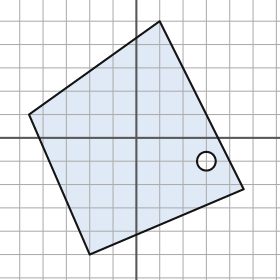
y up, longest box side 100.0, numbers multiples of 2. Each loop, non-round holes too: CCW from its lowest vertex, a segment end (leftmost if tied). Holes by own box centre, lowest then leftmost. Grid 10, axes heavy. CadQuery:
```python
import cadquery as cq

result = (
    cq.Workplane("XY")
    .moveTo(-20.0, -50.0)
    .lineTo(46.0, -22.0)
    .lineTo(10.0, 50.0)
    .lineTo(-46.0, 10.0)
    .close()
    .moveTo(30.0, -10.0)
    .circle(4.0)
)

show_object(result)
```